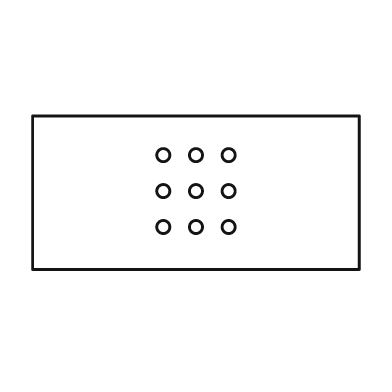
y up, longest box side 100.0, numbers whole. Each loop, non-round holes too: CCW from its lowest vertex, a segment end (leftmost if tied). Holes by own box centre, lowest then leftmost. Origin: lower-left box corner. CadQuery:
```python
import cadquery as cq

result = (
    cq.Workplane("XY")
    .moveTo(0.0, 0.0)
    .lineTo(100.0, 0.0)
    .lineTo(100.0, 47.0)
    .lineTo(0.0, 47.0)
    .close()
    .moveTo(40.0, 13.0)
    .circle(2.0)
    .moveTo(50.0, 13.0)
    .circle(2.0)
    .moveTo(60.0, 13.0)
    .circle(2.0)
    .moveTo(40.0, 24.0)
    .circle(2.0)
    .moveTo(50.0, 24.0)
    .circle(2.0)
    .moveTo(60.0, 24.0)
    .circle(2.0)
    .moveTo(40.0, 35.0)
    .circle(2.0)
    .moveTo(50.0, 35.0)
    .circle(2.0)
    .moveTo(60.0, 35.0)
    .circle(2.0)
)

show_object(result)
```